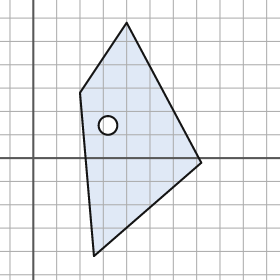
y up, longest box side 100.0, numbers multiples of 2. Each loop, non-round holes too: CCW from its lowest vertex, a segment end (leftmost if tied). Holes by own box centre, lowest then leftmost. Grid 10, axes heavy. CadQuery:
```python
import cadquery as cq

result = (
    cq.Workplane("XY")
    .moveTo(26.0, -42.0)
    .lineTo(72.0, -2.0)
    .lineTo(40.0, 58.0)
    .lineTo(20.0, 28.0)
    .close()
    .moveTo(32.0, 14.0)
    .circle(4.0)
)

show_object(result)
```